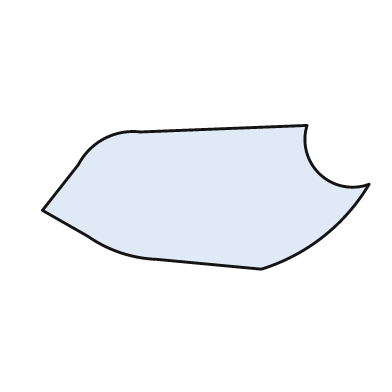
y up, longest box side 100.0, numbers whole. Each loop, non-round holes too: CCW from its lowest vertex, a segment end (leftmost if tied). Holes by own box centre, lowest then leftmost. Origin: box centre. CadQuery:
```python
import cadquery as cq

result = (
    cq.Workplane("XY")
    .moveTo(17.0, -22.0)
    .threePointArc((36.0, -12.0), (50.0, 4.0))
    .threePointArc((35.0, 7.0), (31.0, 22.0))
    .lineTo(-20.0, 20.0)
    .threePointArc((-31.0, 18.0), (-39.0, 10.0))
    .lineTo(-50.0, -4.0)
    .lineTo(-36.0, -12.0)
    .threePointArc((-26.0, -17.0), (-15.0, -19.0))
    .close()
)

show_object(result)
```